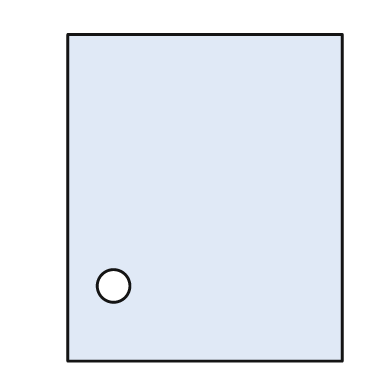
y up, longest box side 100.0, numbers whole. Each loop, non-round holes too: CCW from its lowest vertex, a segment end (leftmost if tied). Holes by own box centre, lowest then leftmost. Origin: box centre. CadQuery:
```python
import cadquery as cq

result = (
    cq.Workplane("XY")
    .moveTo(-42.0, -50.0)
    .lineTo(42.0, -50.0)
    .lineTo(42.0, 50.0)
    .lineTo(-42.0, 50.0)
    .close()
    .moveTo(-28.0, -27.0)
    .circle(5.0)
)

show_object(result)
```